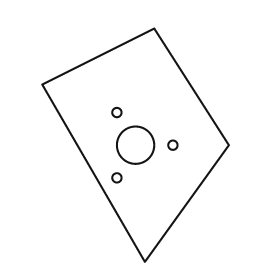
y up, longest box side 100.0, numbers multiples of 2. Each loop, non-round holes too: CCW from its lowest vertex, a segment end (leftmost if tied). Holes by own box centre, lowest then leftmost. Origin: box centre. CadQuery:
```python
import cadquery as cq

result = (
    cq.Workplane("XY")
    .moveTo(4.0, -50.0)
    .lineTo(40.0, 0.0)
    .lineTo(8.0, 50.0)
    .lineTo(-40.0, 26.0)
    .close()
    .moveTo(-8.0, -14.0)
    .circle(2.0)
    .moveTo(0.0, 0.0)
    .circle(8.0)
    .moveTo(16.0, 0.0)
    .circle(2.0)
    .moveTo(-8.0, 14.0)
    .circle(2.0)
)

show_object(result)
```